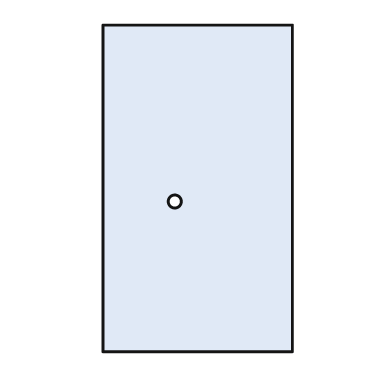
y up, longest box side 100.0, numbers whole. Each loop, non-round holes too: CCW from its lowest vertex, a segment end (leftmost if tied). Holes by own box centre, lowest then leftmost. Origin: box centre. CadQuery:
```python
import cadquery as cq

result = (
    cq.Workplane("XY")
    .moveTo(-29.0, -50.0)
    .lineTo(29.0, -50.0)
    .lineTo(29.0, 50.0)
    .lineTo(-29.0, 50.0)
    .close()
    .moveTo(-7.0, -4.0)
    .circle(2.0)
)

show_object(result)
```